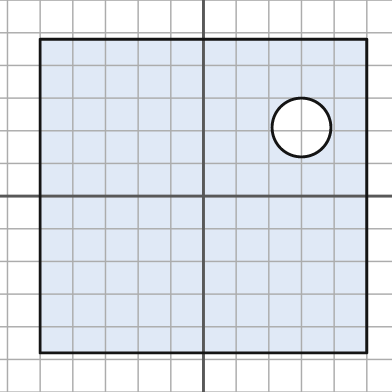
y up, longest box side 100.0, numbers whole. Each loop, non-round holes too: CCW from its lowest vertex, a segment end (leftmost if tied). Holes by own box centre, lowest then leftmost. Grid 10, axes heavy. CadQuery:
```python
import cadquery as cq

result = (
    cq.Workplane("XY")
    .moveTo(-50.0, -48.0)
    .lineTo(50.0, -48.0)
    .lineTo(50.0, 48.0)
    .lineTo(-50.0, 48.0)
    .close()
    .moveTo(30.0, 21.0)
    .circle(9.0)
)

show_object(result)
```